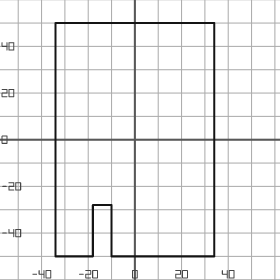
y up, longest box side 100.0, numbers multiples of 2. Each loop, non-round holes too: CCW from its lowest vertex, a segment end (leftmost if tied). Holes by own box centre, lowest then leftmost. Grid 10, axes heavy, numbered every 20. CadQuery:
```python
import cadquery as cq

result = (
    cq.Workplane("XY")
    .moveTo(-34.0, -50.0)
    .lineTo(-18.0, -50.0)
    .lineTo(-18.0, -28.0)
    .lineTo(-10.0, -28.0)
    .lineTo(-10.0, -50.0)
    .lineTo(34.0, -50.0)
    .lineTo(34.0, 50.0)
    .lineTo(-34.0, 50.0)
    .close()
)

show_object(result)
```